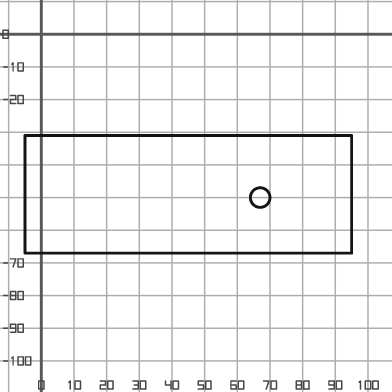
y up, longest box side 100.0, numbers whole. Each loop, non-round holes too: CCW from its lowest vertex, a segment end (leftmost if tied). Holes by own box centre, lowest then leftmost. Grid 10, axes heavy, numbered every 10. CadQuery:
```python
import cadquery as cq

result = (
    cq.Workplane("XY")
    .moveTo(-5.0, -67.0)
    .lineTo(95.0, -67.0)
    .lineTo(95.0, -31.0)
    .lineTo(-5.0, -31.0)
    .close()
    .moveTo(67.0, -50.0)
    .circle(3.0)
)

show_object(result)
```